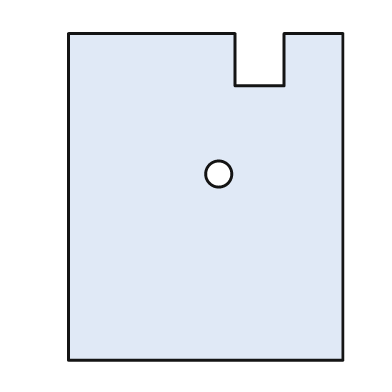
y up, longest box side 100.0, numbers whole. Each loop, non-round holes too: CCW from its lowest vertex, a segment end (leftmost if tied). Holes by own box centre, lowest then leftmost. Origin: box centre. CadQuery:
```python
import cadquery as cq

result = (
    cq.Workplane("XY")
    .moveTo(-42.0, -50.0)
    .lineTo(42.0, -50.0)
    .lineTo(42.0, 50.0)
    .lineTo(24.0, 50.0)
    .lineTo(24.0, 34.0)
    .lineTo(9.0, 34.0)
    .lineTo(9.0, 50.0)
    .lineTo(-42.0, 50.0)
    .close()
    .moveTo(4.0, 7.0)
    .circle(4.0)
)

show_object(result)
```